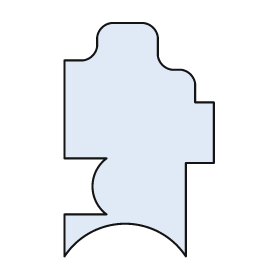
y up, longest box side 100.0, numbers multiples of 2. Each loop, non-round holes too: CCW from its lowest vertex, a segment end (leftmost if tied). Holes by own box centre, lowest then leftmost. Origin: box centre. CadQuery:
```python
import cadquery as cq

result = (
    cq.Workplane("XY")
    .moveTo(-32.0, -50.0)
    .threePointArc((-6.0, -36.0), (20.0, -50.0))
    .lineTo(20.0, -10.0)
    .lineTo(32.0, -10.0)
    .lineTo(32.0, 16.0)
    .lineTo(24.0, 16.0)
    .lineTo(24.0, 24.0)
    .threePointArc((22.0, 28.0), (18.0, 30.0))
    .lineTo(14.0, 30.0)
    .threePointArc((10.0, 32.0), (8.0, 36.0))
    .lineTo(8.0, 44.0)
    .threePointArc((6.0, 48.0), (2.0, 50.0))
    .lineTo(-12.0, 50.0)
    .threePointArc((-16.0, 48.0), (-18.0, 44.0))
    .lineTo(-18.0, 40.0)
    .threePointArc((-20.0, 36.0), (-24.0, 34.0))
    .lineTo(-32.0, 34.0)
    .lineTo(-32.0, -8.0)
    .lineTo(-14.0, -8.0)
    .threePointArc((-20.0, -20.0), (-14.0, -32.0))
    .lineTo(-32.0, -32.0)
    .close()
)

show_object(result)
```